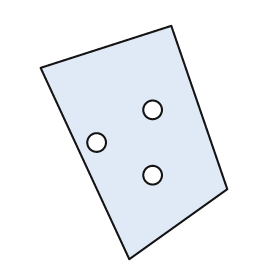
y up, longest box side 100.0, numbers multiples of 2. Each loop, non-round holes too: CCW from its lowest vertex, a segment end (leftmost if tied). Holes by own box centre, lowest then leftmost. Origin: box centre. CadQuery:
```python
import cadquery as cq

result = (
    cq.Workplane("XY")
    .moveTo(-2.0, -50.0)
    .lineTo(40.0, -20.0)
    .lineTo(16.0, 50.0)
    .lineTo(-40.0, 32.0)
    .close()
    .moveTo(8.0, -14.0)
    .circle(4.0)
    .moveTo(-16.0, 0.0)
    .circle(4.0)
    .moveTo(8.0, 14.0)
    .circle(4.0)
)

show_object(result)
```